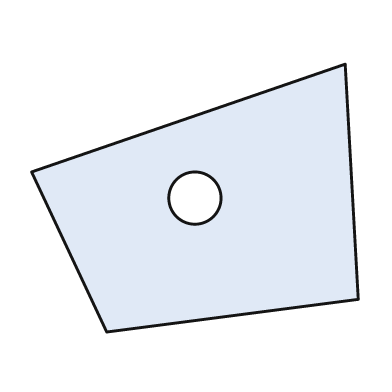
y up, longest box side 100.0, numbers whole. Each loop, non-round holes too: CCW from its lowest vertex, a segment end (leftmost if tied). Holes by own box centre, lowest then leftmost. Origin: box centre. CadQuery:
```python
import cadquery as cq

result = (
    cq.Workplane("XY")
    .moveTo(-27.0, -41.0)
    .lineTo(50.0, -31.0)
    .lineTo(46.0, 41.0)
    .lineTo(-50.0, 8.0)
    .close()
    .moveTo(0.0, 0.0)
    .circle(8.0)
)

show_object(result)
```